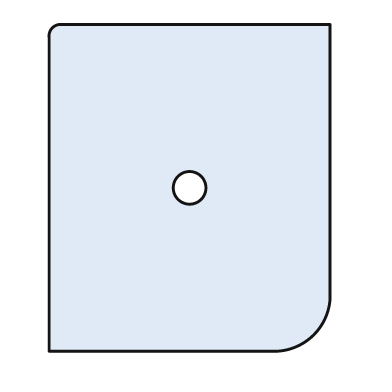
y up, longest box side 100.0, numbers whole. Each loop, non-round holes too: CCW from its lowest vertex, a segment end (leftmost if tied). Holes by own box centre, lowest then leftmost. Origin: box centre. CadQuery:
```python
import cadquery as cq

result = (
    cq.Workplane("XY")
    .moveTo(-43.0, -50.0)
    .lineTo(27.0, -50.0)
    .threePointArc((38.0, -45.0), (43.0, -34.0))
    .lineTo(43.0, 50.0)
    .lineTo(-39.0, 50.0)
    .threePointArc((-42.0, 49.0), (-43.0, 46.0))
    .close()
    .moveTo(0.0, 0.0)
    .circle(5.0)
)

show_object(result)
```